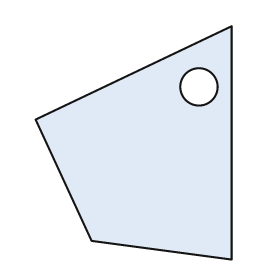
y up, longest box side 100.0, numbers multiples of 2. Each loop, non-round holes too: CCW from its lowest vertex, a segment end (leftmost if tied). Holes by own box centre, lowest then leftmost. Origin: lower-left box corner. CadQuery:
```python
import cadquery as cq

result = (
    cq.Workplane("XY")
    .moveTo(84.0, 0.0)
    .lineTo(84.0, 100.0)
    .lineTo(0.0, 60.0)
    .lineTo(24.0, 8.0)
    .close()
    .moveTo(70.0, 74.0)
    .circle(8.0)
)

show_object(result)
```